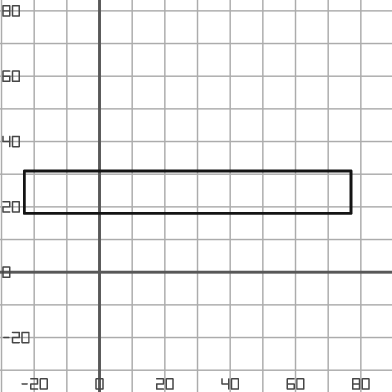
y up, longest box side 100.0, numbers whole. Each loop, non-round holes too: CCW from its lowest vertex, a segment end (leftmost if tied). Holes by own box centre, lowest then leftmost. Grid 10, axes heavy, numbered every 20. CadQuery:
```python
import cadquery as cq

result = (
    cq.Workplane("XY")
    .moveTo(-23.0, 18.0)
    .lineTo(77.0, 18.0)
    .lineTo(77.0, 31.0)
    .lineTo(-23.0, 31.0)
    .close()
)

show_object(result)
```